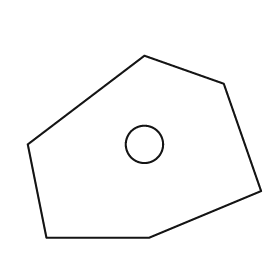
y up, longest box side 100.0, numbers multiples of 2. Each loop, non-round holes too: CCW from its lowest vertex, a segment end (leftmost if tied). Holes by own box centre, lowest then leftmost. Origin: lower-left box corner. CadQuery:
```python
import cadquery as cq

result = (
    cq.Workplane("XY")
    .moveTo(8.0, 0.0)
    .lineTo(52.0, 0.0)
    .lineTo(100.0, 20.0)
    .lineTo(84.0, 66.0)
    .lineTo(50.0, 78.0)
    .lineTo(0.0, 40.0)
    .close()
    .moveTo(50.0, 40.0)
    .circle(8.0)
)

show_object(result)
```